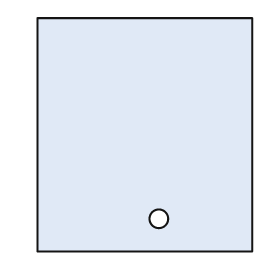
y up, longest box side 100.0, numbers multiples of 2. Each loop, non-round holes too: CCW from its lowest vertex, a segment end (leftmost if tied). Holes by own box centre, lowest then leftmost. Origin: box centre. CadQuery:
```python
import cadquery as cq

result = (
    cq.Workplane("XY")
    .moveTo(-46.0, -50.0)
    .lineTo(46.0, -50.0)
    .lineTo(46.0, 50.0)
    .lineTo(-46.0, 50.0)
    .close()
    .moveTo(6.0, -36.0)
    .circle(4.0)
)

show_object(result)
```